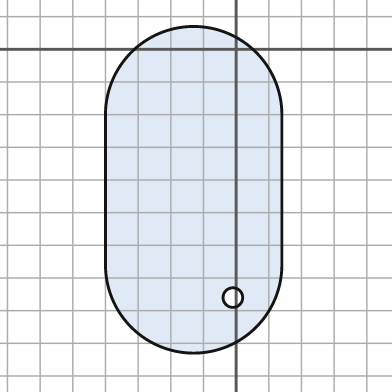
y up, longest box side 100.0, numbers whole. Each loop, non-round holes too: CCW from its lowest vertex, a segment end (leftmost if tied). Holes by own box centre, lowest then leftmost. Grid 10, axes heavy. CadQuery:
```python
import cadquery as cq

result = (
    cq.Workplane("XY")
    .moveTo(-40.0, -66.0)
    .threePointArc((-13.0, -93.0), (14.0, -66.0))
    .lineTo(14.0, -20.0)
    .threePointArc((-13.0, 7.0), (-40.0, -20.0))
    .close()
    .moveTo(-1.0, -76.0)
    .circle(3.0)
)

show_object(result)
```